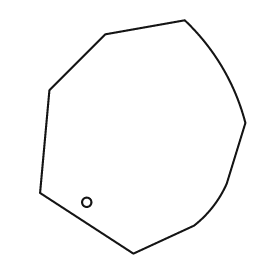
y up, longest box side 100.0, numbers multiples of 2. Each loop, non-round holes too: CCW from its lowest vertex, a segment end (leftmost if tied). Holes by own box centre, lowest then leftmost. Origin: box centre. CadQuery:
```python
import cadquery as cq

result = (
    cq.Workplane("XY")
    .moveTo(-4.0, -50.0)
    .lineTo(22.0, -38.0)
    .threePointArc((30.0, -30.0), (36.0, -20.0))
    .lineTo(44.0, 6.0)
    .threePointArc((34.0, 30.0), (18.0, 50.0))
    .lineTo(-16.0, 44.0)
    .lineTo(-40.0, 20.0)
    .lineTo(-44.0, -24.0)
    .close()
    .moveTo(-24.0, -28.0)
    .circle(2.0)
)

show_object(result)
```